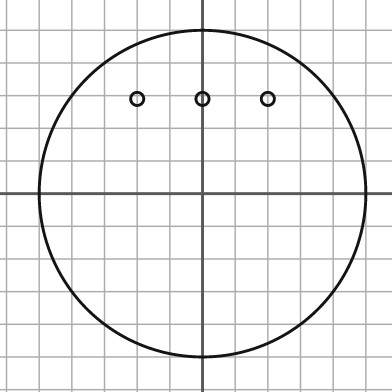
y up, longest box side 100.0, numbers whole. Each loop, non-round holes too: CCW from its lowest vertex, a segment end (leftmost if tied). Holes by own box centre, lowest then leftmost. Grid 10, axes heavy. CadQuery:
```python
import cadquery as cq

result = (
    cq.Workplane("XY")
    .moveTo(0.0, 0.0)
    .circle(50.0)
    .moveTo(-20.0, 29.0)
    .circle(2.0)
    .moveTo(0.0, 29.0)
    .circle(2.0)
    .moveTo(20.0, 29.0)
    .circle(2.0)
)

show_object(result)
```